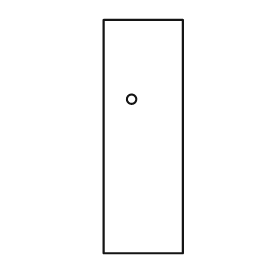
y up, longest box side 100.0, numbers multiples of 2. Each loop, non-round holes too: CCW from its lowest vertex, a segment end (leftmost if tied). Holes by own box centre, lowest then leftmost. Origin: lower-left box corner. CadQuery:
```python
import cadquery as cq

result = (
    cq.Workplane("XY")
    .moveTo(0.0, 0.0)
    .lineTo(34.0, 0.0)
    .lineTo(34.0, 100.0)
    .lineTo(0.0, 100.0)
    .close()
    .moveTo(12.0, 66.0)
    .circle(2.0)
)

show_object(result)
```